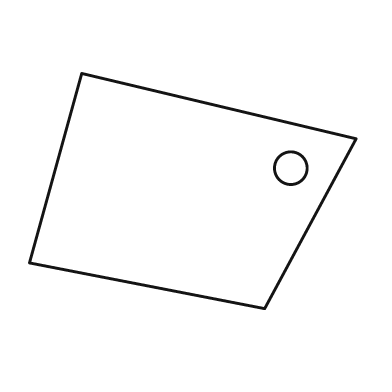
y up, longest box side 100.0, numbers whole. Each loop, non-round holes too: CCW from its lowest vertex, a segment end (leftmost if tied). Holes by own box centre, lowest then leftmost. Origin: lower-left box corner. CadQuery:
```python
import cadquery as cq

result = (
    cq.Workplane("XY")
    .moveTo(72.0, 0.0)
    .lineTo(100.0, 52.0)
    .lineTo(16.0, 72.0)
    .lineTo(0.0, 14.0)
    .close()
    .moveTo(80.0, 43.0)
    .circle(5.0)
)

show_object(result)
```